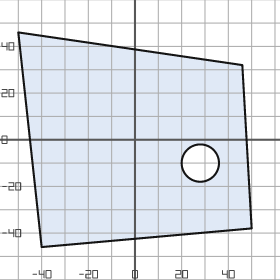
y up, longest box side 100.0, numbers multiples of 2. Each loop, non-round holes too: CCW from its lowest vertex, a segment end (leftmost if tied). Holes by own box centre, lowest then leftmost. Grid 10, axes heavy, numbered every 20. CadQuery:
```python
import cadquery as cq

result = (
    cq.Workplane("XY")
    .moveTo(-40.0, -46.0)
    .lineTo(50.0, -38.0)
    .lineTo(46.0, 32.0)
    .lineTo(-50.0, 46.0)
    .close()
    .moveTo(28.0, -10.0)
    .circle(8.0)
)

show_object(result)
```